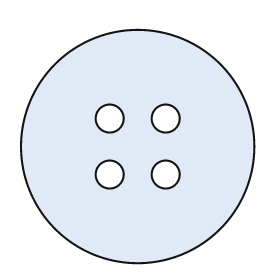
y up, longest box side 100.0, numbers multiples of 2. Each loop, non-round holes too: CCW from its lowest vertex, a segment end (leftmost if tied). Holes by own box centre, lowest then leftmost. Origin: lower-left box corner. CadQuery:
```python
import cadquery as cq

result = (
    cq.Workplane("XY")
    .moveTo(50.0, 50.0)
    .circle(50.0)
    .moveTo(38.0, 38.0)
    .circle(6.0)
    .moveTo(62.0, 38.0)
    .circle(6.0)
    .moveTo(38.0, 62.0)
    .circle(6.0)
    .moveTo(62.0, 62.0)
    .circle(6.0)
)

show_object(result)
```